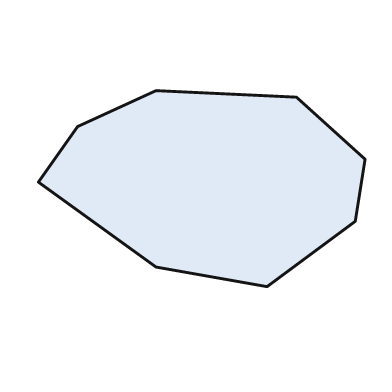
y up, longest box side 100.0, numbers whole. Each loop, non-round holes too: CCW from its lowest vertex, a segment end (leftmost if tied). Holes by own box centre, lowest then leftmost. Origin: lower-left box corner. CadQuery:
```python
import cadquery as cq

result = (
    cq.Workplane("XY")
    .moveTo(70.0, 0.0)
    .lineTo(97.0, 20.0)
    .lineTo(100.0, 39.0)
    .lineTo(79.0, 58.0)
    .lineTo(36.0, 60.0)
    .lineTo(12.0, 49.0)
    .lineTo(0.0, 32.0)
    .lineTo(36.0, 6.0)
    .close()
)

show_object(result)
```